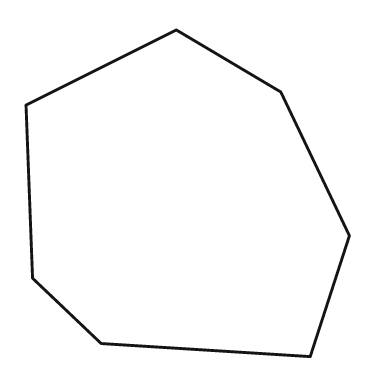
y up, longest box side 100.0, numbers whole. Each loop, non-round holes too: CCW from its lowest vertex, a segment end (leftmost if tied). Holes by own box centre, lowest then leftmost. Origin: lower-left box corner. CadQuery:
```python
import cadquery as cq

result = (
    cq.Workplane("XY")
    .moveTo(87.0, 0.0)
    .lineTo(99.0, 37.0)
    .lineTo(78.0, 81.0)
    .lineTo(46.0, 100.0)
    .lineTo(0.0, 77.0)
    .lineTo(2.0, 24.0)
    .lineTo(23.0, 4.0)
    .close()
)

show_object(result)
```